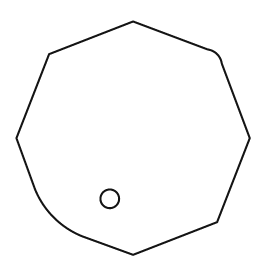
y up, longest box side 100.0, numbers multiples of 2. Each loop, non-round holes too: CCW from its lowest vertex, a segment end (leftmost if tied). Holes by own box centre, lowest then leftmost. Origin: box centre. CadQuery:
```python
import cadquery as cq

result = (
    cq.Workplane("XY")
    .moveTo(0.0, -50.0)
    .lineTo(36.0, -36.0)
    .lineTo(50.0, 0.0)
    .lineTo(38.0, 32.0)
    .threePointArc((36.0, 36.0), (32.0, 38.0))
    .lineTo(0.0, 50.0)
    .lineTo(-36.0, 36.0)
    .lineTo(-50.0, 0.0)
    .lineTo(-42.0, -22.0)
    .threePointArc((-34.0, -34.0), (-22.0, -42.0))
    .close()
    .moveTo(-10.0, -26.0)
    .circle(4.0)
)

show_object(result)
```